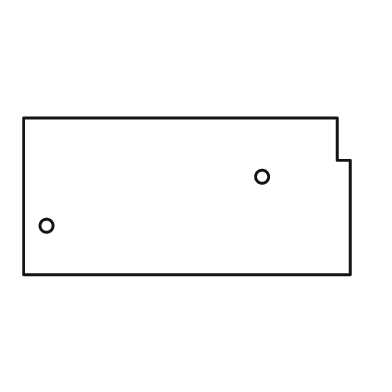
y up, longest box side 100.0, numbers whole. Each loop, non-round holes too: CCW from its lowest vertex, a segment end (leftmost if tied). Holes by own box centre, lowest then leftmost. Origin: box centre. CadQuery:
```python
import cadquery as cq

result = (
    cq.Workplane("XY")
    .moveTo(-50.0, -24.0)
    .lineTo(50.0, -24.0)
    .lineTo(50.0, 11.0)
    .lineTo(46.0, 11.0)
    .lineTo(46.0, 24.0)
    .lineTo(-50.0, 24.0)
    .close()
    .moveTo(-43.0, -9.0)
    .circle(2.0)
    .moveTo(23.0, 6.0)
    .circle(2.0)
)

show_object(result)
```